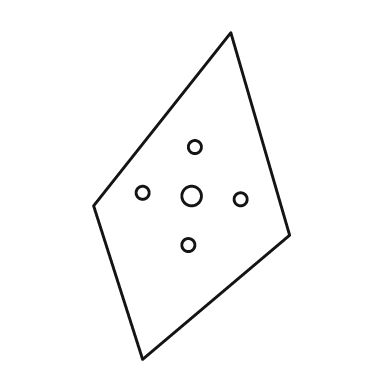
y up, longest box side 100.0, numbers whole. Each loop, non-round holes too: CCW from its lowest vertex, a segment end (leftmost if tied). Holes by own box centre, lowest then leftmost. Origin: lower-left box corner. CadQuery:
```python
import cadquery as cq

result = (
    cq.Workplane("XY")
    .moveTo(15.0, 0.0)
    .lineTo(60.0, 38.0)
    .lineTo(42.0, 100.0)
    .lineTo(0.0, 47.0)
    .close()
    .moveTo(29.0, 35.0)
    .circle(2.0)
    .moveTo(45.0, 49.0)
    .circle(2.0)
    .moveTo(30.0, 50.0)
    .circle(3.0)
    .moveTo(15.0, 51.0)
    .circle(2.0)
    .moveTo(31.0, 65.0)
    .circle(2.0)
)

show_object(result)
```